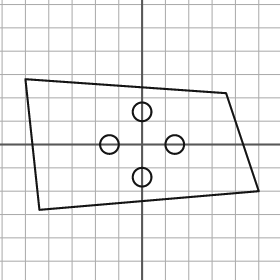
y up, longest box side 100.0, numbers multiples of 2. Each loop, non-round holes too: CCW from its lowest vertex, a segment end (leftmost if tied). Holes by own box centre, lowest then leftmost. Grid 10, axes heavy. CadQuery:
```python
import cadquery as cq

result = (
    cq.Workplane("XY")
    .moveTo(-44.0, -28.0)
    .lineTo(50.0, -20.0)
    .lineTo(36.0, 22.0)
    .lineTo(-50.0, 28.0)
    .close()
    .moveTo(0.0, -14.0)
    .circle(4.0)
    .moveTo(-14.0, 0.0)
    .circle(4.0)
    .moveTo(14.0, 0.0)
    .circle(4.0)
    .moveTo(0.0, 14.0)
    .circle(4.0)
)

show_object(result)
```